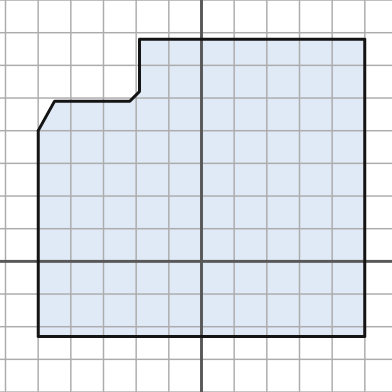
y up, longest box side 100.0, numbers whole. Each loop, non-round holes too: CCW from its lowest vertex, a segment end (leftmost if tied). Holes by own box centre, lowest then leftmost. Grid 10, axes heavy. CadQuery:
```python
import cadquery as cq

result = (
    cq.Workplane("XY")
    .moveTo(-50.0, -23.0)
    .lineTo(50.0, -23.0)
    .lineTo(50.0, 68.0)
    .lineTo(-19.0, 68.0)
    .lineTo(-19.0, 52.0)
    .lineTo(-22.0, 49.0)
    .lineTo(-45.0, 49.0)
    .lineTo(-50.0, 40.0)
    .close()
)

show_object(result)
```